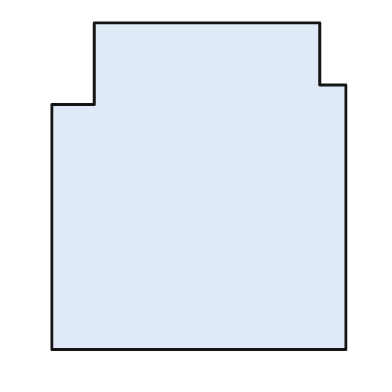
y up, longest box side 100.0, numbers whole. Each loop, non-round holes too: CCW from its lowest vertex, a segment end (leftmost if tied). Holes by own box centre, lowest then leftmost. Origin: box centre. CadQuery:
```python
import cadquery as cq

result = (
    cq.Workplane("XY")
    .moveTo(-45.0, -50.0)
    .lineTo(45.0, -50.0)
    .lineTo(45.0, 31.0)
    .lineTo(37.0, 31.0)
    .lineTo(37.0, 50.0)
    .lineTo(-32.0, 50.0)
    .lineTo(-32.0, 25.0)
    .lineTo(-45.0, 25.0)
    .close()
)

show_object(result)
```